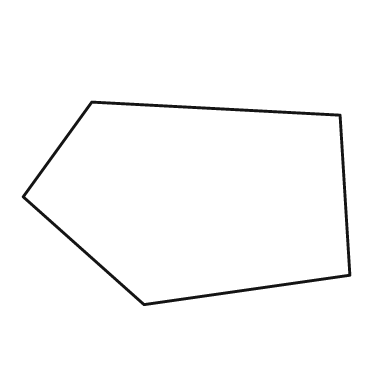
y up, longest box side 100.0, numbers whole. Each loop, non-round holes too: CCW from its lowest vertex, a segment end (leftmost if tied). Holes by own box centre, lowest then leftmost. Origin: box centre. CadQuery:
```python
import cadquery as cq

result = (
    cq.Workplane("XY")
    .moveTo(-13.0, -31.0)
    .lineTo(50.0, -22.0)
    .lineTo(47.0, 27.0)
    .lineTo(-29.0, 31.0)
    .lineTo(-50.0, 2.0)
    .close()
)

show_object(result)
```